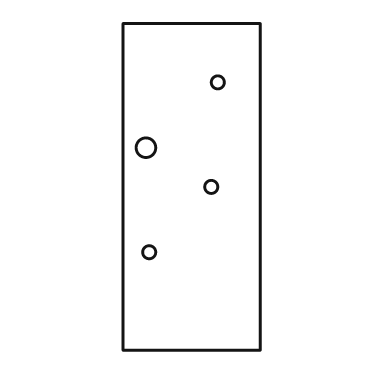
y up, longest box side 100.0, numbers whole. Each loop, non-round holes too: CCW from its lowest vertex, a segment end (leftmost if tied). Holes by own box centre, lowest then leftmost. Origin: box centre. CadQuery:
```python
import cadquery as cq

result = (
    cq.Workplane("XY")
    .moveTo(-21.0, -50.0)
    .lineTo(21.0, -50.0)
    .lineTo(21.0, 50.0)
    .lineTo(-21.0, 50.0)
    .close()
    .moveTo(-13.0, -20.0)
    .circle(2.0)
    .moveTo(6.0, 0.0)
    .circle(2.0)
    .moveTo(-14.0, 12.0)
    .circle(3.0)
    .moveTo(8.0, 32.0)
    .circle(2.0)
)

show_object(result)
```